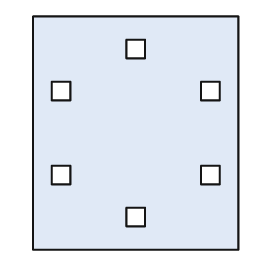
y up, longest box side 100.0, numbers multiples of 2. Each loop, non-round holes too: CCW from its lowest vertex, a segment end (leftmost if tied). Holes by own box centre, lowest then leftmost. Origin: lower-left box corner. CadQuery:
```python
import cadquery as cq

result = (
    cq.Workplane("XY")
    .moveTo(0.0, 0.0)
    .lineTo(88.0, 0.0)
    .lineTo(88.0, 100.0)
    .lineTo(0.0, 100.0)
    .close()
    .moveTo(40.0, 10.0)
    .lineTo(48.0, 10.0)
    .lineTo(48.0, 18.0)
    .lineTo(40.0, 18.0)
    .close()
    .moveTo(8.0, 28.0)
    .lineTo(16.0, 28.0)
    .lineTo(16.0, 36.0)
    .lineTo(8.0, 36.0)
    .close()
    .moveTo(72.0, 28.0)
    .lineTo(80.0, 28.0)
    .lineTo(80.0, 36.0)
    .lineTo(72.0, 36.0)
    .close()
    .moveTo(8.0, 64.0)
    .lineTo(16.0, 64.0)
    .lineTo(16.0, 72.0)
    .lineTo(8.0, 72.0)
    .close()
    .moveTo(72.0, 64.0)
    .lineTo(80.0, 64.0)
    .lineTo(80.0, 72.0)
    .lineTo(72.0, 72.0)
    .close()
    .moveTo(40.0, 82.0)
    .lineTo(48.0, 82.0)
    .lineTo(48.0, 90.0)
    .lineTo(40.0, 90.0)
    .close()
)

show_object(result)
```